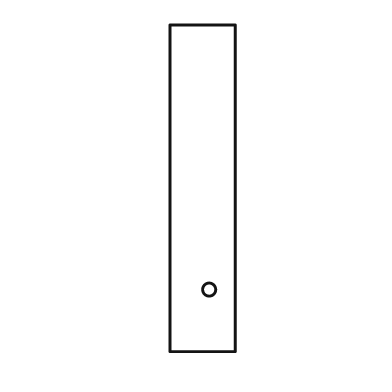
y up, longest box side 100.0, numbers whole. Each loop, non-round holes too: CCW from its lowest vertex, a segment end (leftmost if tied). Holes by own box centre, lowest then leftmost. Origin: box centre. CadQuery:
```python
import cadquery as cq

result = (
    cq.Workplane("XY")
    .moveTo(-10.0, -50.0)
    .lineTo(10.0, -50.0)
    .lineTo(10.0, 50.0)
    .lineTo(-10.0, 50.0)
    .close()
    .moveTo(2.0, -31.0)
    .circle(2.0)
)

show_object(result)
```